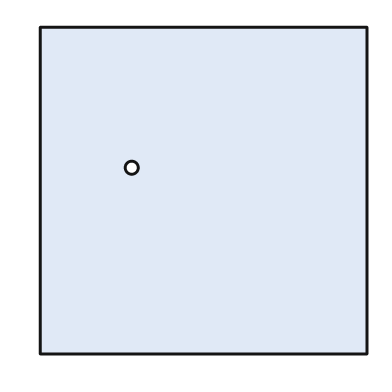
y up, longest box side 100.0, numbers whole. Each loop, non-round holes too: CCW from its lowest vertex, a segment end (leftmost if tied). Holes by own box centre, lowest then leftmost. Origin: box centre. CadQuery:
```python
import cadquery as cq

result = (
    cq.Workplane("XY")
    .moveTo(-50.0, -50.0)
    .lineTo(50.0, -50.0)
    .lineTo(50.0, 50.0)
    .lineTo(-50.0, 50.0)
    .close()
    .moveTo(-22.0, 7.0)
    .circle(2.0)
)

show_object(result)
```